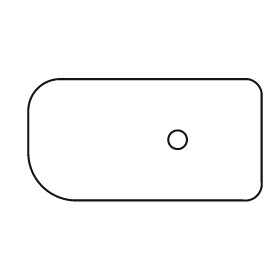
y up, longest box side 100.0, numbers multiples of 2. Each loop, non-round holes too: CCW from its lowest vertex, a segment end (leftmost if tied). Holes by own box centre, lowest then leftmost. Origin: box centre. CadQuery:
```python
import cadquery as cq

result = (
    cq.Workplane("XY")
    .moveTo(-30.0, -26.0)
    .lineTo(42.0, -26.0)
    .threePointArc((48.0, -24.0), (50.0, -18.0))
    .lineTo(50.0, 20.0)
    .threePointArc((48.0, 24.0), (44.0, 26.0))
    .lineTo(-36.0, 26.0)
    .threePointArc((-46.0, 22.0), (-50.0, 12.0))
    .lineTo(-50.0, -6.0)
    .threePointArc((-44.0, -20.0), (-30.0, -26.0))
    .close()
    .moveTo(14.0, 0.0)
    .circle(4.0)
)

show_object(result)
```